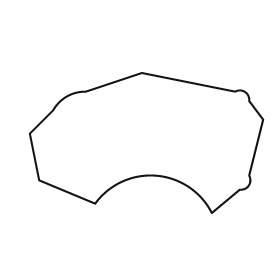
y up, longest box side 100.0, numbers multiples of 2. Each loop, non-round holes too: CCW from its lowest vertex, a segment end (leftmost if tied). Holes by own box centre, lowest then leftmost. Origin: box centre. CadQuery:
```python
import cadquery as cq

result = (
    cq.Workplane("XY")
    .moveTo(28.0, -30.0)
    .lineTo(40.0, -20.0)
    .threePointArc((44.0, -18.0), (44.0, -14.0))
    .lineTo(50.0, 10.0)
    .lineTo(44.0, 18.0)
    .threePointArc((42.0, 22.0), (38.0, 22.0))
    .lineTo(-2.0, 30.0)
    .lineTo(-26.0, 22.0)
    .threePointArc((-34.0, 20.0), (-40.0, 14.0))
    .lineTo(-50.0, 4.0)
    .lineTo(-46.0, -16.0)
    .lineTo(-22.0, -26.0)
    .threePointArc((4.0, -14.0), (28.0, -30.0))
    .close()
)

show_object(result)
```